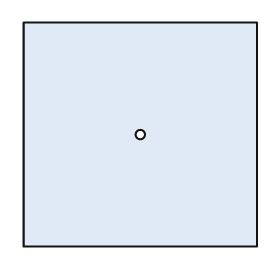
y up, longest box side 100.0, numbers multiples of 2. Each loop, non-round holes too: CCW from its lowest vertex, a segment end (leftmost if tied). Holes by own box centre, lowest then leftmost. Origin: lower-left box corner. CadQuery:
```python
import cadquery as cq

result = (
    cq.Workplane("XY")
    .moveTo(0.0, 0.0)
    .lineTo(100.0, 0.0)
    .lineTo(100.0, 96.0)
    .lineTo(0.0, 96.0)
    .close()
    .moveTo(50.0, 48.0)
    .circle(2.0)
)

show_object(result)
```